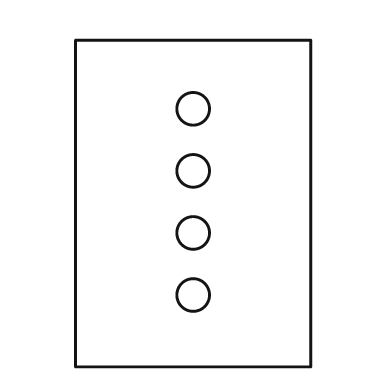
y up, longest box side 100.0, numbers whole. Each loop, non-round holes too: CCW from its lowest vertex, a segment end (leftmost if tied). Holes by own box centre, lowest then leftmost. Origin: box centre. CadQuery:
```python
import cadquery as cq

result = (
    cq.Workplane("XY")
    .moveTo(-36.0, -50.0)
    .lineTo(36.0, -50.0)
    .lineTo(36.0, 50.0)
    .lineTo(-36.0, 50.0)
    .close()
    .moveTo(0.0, -28.0)
    .circle(5.0)
    .moveTo(0.0, -9.0)
    .circle(5.0)
    .moveTo(0.0, 10.0)
    .circle(5.0)
    .moveTo(0.0, 29.0)
    .circle(5.0)
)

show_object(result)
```